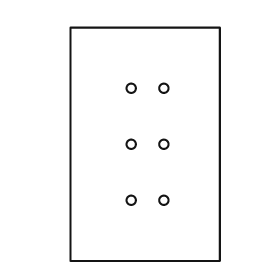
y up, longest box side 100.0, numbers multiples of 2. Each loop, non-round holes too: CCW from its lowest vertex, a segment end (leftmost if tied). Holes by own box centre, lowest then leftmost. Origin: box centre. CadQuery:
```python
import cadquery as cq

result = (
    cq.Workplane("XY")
    .moveTo(-32.0, -50.0)
    .lineTo(32.0, -50.0)
    .lineTo(32.0, 50.0)
    .lineTo(-32.0, 50.0)
    .close()
    .moveTo(-6.0, -24.0)
    .circle(2.0)
    .moveTo(8.0, -24.0)
    .circle(2.0)
    .moveTo(-6.0, 0.0)
    .circle(2.0)
    .moveTo(8.0, 0.0)
    .circle(2.0)
    .moveTo(-6.0, 24.0)
    .circle(2.0)
    .moveTo(8.0, 24.0)
    .circle(2.0)
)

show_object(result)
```